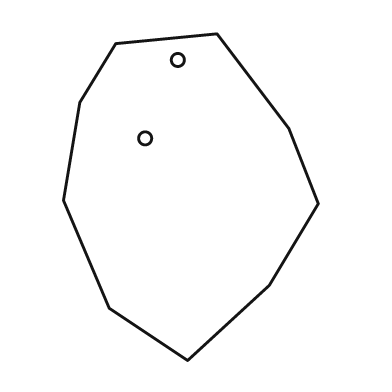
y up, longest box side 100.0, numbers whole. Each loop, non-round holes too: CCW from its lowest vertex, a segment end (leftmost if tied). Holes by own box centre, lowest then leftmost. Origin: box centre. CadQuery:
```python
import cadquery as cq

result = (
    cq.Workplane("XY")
    .moveTo(-1.0, -50.0)
    .lineTo(24.0, -27.0)
    .lineTo(39.0, -2.0)
    .lineTo(30.0, 21.0)
    .lineTo(8.0, 50.0)
    .lineTo(-23.0, 47.0)
    .lineTo(-34.0, 29.0)
    .lineTo(-39.0, -1.0)
    .lineTo(-25.0, -34.0)
    .close()
    .moveTo(-14.0, 18.0)
    .circle(2.0)
    .moveTo(-4.0, 42.0)
    .circle(2.0)
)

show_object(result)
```